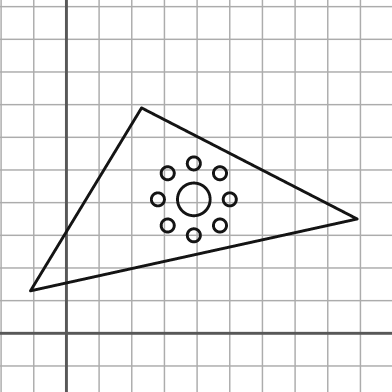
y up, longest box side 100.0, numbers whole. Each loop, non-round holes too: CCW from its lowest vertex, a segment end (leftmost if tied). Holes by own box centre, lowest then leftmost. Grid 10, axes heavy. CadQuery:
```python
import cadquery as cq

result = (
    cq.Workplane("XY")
    .moveTo(-11.0, 13.0)
    .lineTo(89.0, 35.0)
    .lineTo(23.0, 69.0)
    .close()
    .moveTo(39.0, 30.0)
    .circle(2.0)
    .moveTo(31.0, 33.0)
    .circle(2.0)
    .moveTo(47.0, 33.0)
    .circle(2.0)
    .moveTo(28.0, 41.0)
    .circle(2.0)
    .moveTo(39.0, 41.0)
    .circle(5.0)
    .moveTo(50.0, 41.0)
    .circle(2.0)
    .moveTo(31.0, 49.0)
    .circle(2.0)
    .moveTo(47.0, 49.0)
    .circle(2.0)
    .moveTo(39.0, 52.0)
    .circle(2.0)
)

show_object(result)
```